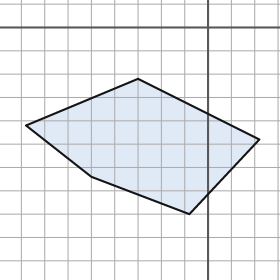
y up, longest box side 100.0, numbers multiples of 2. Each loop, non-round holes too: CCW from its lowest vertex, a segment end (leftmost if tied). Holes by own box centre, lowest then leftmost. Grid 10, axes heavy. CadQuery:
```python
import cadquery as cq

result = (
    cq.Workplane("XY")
    .moveTo(-8.0, -80.0)
    .lineTo(22.0, -48.0)
    .lineTo(-30.0, -22.0)
    .lineTo(-78.0, -42.0)
    .lineTo(-50.0, -64.0)
    .close()
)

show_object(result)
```